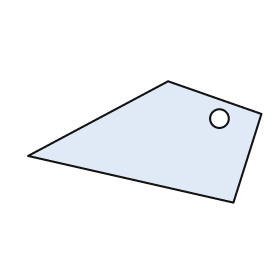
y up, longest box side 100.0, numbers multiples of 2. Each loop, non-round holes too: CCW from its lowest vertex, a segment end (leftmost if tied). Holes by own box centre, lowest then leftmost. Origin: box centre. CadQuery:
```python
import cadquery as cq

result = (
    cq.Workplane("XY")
    .moveTo(38.0, -26.0)
    .lineTo(50.0, 12.0)
    .lineTo(10.0, 26.0)
    .lineTo(-50.0, -6.0)
    .close()
    .moveTo(32.0, 10.0)
    .circle(4.0)
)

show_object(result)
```